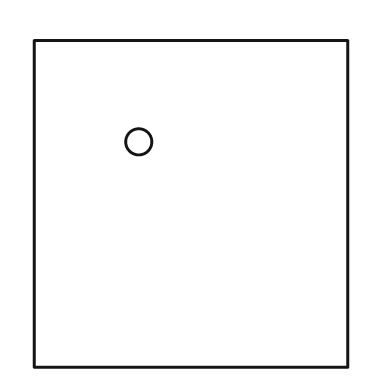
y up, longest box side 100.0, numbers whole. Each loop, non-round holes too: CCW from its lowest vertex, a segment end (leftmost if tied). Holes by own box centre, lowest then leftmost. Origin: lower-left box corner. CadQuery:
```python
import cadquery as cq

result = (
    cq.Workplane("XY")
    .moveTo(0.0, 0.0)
    .lineTo(96.0, 0.0)
    .lineTo(96.0, 100.0)
    .lineTo(0.0, 100.0)
    .close()
    .moveTo(32.0, 69.0)
    .circle(4.0)
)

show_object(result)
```